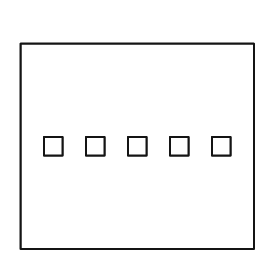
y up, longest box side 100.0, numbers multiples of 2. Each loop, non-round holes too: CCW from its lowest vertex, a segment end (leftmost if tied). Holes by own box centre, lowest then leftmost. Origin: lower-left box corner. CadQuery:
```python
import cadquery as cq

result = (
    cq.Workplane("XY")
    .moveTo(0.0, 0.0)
    .lineTo(100.0, 0.0)
    .lineTo(100.0, 88.0)
    .lineTo(0.0, 88.0)
    .close()
    .moveTo(10.0, 40.0)
    .lineTo(18.0, 40.0)
    .lineTo(18.0, 48.0)
    .lineTo(10.0, 48.0)
    .close()
    .moveTo(28.0, 40.0)
    .lineTo(36.0, 40.0)
    .lineTo(36.0, 48.0)
    .lineTo(28.0, 48.0)
    .close()
    .moveTo(46.0, 40.0)
    .lineTo(54.0, 40.0)
    .lineTo(54.0, 48.0)
    .lineTo(46.0, 48.0)
    .close()
    .moveTo(64.0, 40.0)
    .lineTo(72.0, 40.0)
    .lineTo(72.0, 48.0)
    .lineTo(64.0, 48.0)
    .close()
    .moveTo(82.0, 40.0)
    .lineTo(90.0, 40.0)
    .lineTo(90.0, 48.0)
    .lineTo(82.0, 48.0)
    .close()
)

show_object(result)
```